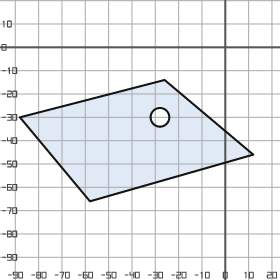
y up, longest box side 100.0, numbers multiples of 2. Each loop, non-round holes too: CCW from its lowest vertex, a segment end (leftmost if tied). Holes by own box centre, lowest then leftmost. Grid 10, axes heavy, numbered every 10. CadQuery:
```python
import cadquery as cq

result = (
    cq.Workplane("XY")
    .moveTo(-58.0, -66.0)
    .lineTo(12.0, -46.0)
    .lineTo(-26.0, -14.0)
    .lineTo(-88.0, -30.0)
    .close()
    .moveTo(-28.0, -30.0)
    .circle(4.0)
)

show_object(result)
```